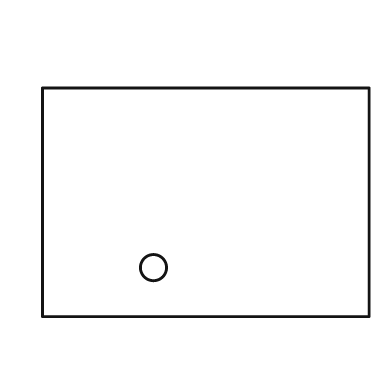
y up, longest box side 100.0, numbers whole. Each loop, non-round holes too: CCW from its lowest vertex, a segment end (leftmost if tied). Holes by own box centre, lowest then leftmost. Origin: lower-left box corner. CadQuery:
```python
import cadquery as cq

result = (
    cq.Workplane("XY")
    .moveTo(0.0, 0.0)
    .lineTo(100.0, 0.0)
    .lineTo(100.0, 70.0)
    .lineTo(0.0, 70.0)
    .close()
    .moveTo(34.0, 15.0)
    .circle(4.0)
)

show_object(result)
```